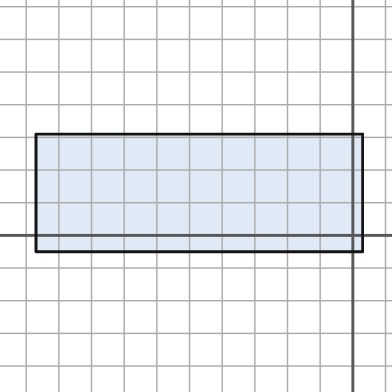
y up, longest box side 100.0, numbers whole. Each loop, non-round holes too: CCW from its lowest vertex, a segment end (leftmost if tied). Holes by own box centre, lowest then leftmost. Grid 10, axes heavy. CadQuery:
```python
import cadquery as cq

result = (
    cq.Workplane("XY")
    .moveTo(-97.0, -5.0)
    .lineTo(3.0, -5.0)
    .lineTo(3.0, 31.0)
    .lineTo(-97.0, 31.0)
    .close()
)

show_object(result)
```